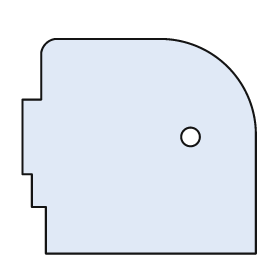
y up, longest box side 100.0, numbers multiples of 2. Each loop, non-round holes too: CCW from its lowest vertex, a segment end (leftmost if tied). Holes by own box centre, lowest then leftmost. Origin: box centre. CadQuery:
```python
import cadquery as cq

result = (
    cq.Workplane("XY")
    .moveTo(-40.0, -46.0)
    .lineTo(50.0, -46.0)
    .lineTo(50.0, 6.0)
    .threePointArc((38.0, 34.0), (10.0, 46.0))
    .lineTo(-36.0, 46.0)
    .threePointArc((-40.0, 44.0), (-42.0, 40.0))
    .lineTo(-42.0, 20.0)
    .lineTo(-50.0, 20.0)
    .lineTo(-50.0, -12.0)
    .lineTo(-46.0, -12.0)
    .lineTo(-46.0, -26.0)
    .lineTo(-40.0, -26.0)
    .close()
    .moveTo(22.0, 4.0)
    .circle(4.0)
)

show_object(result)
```